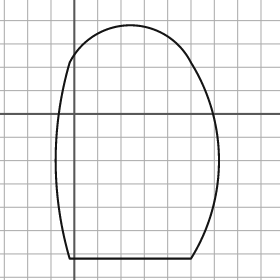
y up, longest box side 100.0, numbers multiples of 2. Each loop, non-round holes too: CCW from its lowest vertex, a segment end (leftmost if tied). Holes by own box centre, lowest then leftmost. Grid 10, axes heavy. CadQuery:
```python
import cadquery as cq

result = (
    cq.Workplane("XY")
    .moveTo(-2.0, -62.0)
    .lineTo(50.0, -62.0)
    .threePointArc((62.0, -20.0), (50.0, 22.0))
    .threePointArc((24.0, 38.0), (-2.0, 22.0))
    .threePointArc((-8.0, -20.0), (-2.0, -62.0))
    .close()
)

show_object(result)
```